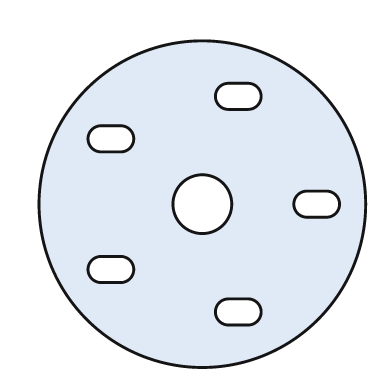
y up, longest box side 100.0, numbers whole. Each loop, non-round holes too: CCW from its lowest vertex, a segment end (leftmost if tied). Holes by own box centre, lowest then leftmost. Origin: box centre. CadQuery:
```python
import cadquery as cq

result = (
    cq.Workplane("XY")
    .moveTo(0.0, 0.0)
    .circle(50.0)
    .moveTo(8.0, -37.0)
    .lineTo(14.0, -37.0)
    .threePointArc((18.0, -33.0), (14.0, -29.0))
    .lineTo(8.0, -29.0)
    .threePointArc((4.0, -33.0), (8.0, -37.0))
    .close()
    .moveTo(-31.0, -24.0)
    .lineTo(-25.0, -24.0)
    .threePointArc((-21.0, -20.0), (-25.0, -16.0))
    .lineTo(-31.0, -16.0)
    .threePointArc((-35.0, -20.0), (-31.0, -24.0))
    .close()
    .moveTo(0.0, 0.0)
    .circle(9.0)
    .moveTo(32.0, -4.0)
    .lineTo(38.0, -4.0)
    .threePointArc((42.0, 0.0), (38.0, 4.0))
    .lineTo(32.0, 4.0)
    .threePointArc((28.0, 0.0), (32.0, -4.0))
    .close()
    .moveTo(-31.0, 16.0)
    .lineTo(-25.0, 16.0)
    .threePointArc((-21.0, 20.0), (-25.0, 24.0))
    .lineTo(-31.0, 24.0)
    .threePointArc((-35.0, 20.0), (-31.0, 16.0))
    .close()
    .moveTo(8.0, 29.0)
    .lineTo(14.0, 29.0)
    .threePointArc((18.0, 33.0), (14.0, 37.0))
    .lineTo(8.0, 37.0)
    .threePointArc((4.0, 33.0), (8.0, 29.0))
    .close()
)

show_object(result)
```